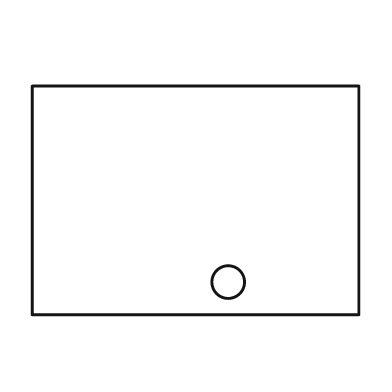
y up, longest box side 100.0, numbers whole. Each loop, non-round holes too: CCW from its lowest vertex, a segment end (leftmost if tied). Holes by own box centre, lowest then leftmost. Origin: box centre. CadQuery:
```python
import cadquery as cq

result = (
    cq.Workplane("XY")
    .moveTo(-50.0, -35.0)
    .lineTo(50.0, -35.0)
    .lineTo(50.0, 35.0)
    .lineTo(-50.0, 35.0)
    .close()
    .moveTo(10.0, -25.0)
    .circle(5.0)
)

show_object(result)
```